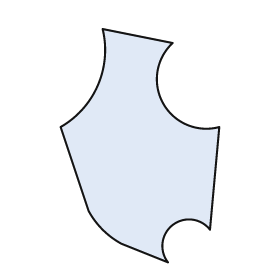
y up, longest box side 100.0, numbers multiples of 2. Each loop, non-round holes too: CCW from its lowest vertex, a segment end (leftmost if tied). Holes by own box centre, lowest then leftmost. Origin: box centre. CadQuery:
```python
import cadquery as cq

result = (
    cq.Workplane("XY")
    .moveTo(12.0, -50.0)
    .threePointArc((14.0, -34.0), (30.0, -36.0))
    .lineTo(34.0, 8.0)
    .threePointArc((10.0, 18.0), (14.0, 44.0))
    .lineTo(-16.0, 50.0)
    .threePointArc((-18.0, 26.0), (-34.0, 8.0))
    .lineTo(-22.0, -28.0)
    .threePointArc((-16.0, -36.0), (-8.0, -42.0))
    .close()
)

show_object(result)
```